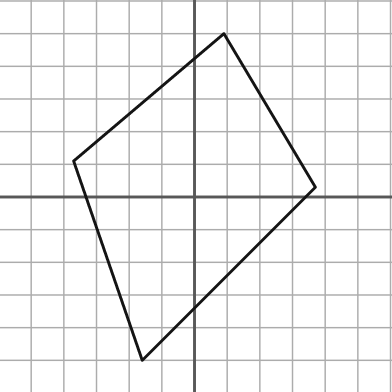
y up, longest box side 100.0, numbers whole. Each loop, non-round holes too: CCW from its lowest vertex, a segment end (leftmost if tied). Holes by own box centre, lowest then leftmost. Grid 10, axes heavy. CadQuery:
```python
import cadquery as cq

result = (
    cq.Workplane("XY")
    .moveTo(-16.0, -50.0)
    .lineTo(37.0, 3.0)
    .lineTo(9.0, 50.0)
    .lineTo(-37.0, 11.0)
    .close()
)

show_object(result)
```